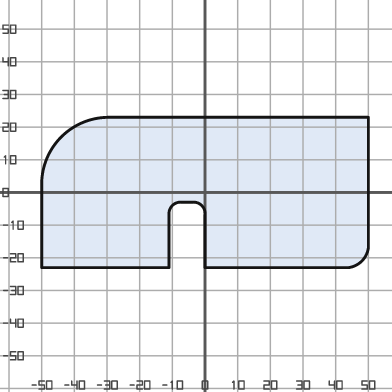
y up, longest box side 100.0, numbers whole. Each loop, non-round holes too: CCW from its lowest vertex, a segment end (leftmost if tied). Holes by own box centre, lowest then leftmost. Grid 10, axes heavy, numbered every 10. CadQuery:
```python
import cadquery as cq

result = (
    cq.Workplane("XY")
    .moveTo(-50.0, -23.0)
    .lineTo(-11.0, -23.0)
    .lineTo(-11.0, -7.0)
    .threePointArc((-10.0, -4.0), (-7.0, -3.0))
    .lineTo(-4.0, -3.0)
    .threePointArc((-1.0, -4.0), (0.0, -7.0))
    .lineTo(0.0, -23.0)
    .lineTo(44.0, -23.0)
    .threePointArc((48.0, -21.0), (50.0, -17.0))
    .lineTo(50.0, 23.0)
    .lineTo(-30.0, 23.0)
    .threePointArc((-44.0, 17.0), (-50.0, 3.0))
    .close()
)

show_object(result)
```